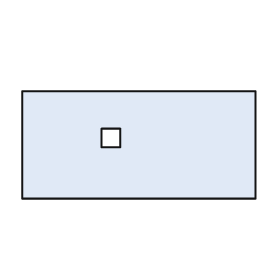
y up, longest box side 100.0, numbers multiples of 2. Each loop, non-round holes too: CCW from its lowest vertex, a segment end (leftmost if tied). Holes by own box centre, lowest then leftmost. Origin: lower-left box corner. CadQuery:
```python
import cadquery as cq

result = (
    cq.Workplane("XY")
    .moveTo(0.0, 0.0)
    .lineTo(100.0, 0.0)
    .lineTo(100.0, 46.0)
    .lineTo(0.0, 46.0)
    .close()
    .moveTo(34.0, 22.0)
    .lineTo(42.0, 22.0)
    .lineTo(42.0, 30.0)
    .lineTo(34.0, 30.0)
    .close()
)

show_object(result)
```